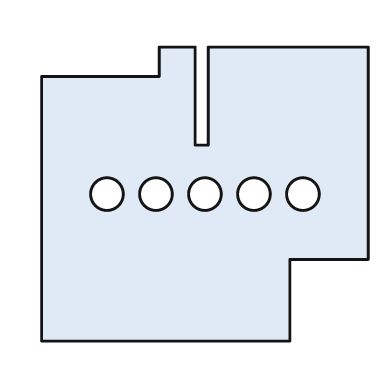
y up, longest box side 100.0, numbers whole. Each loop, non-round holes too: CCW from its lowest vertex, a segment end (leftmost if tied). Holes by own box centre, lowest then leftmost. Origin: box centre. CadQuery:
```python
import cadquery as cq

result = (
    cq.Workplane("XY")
    .moveTo(-50.0, -45.0)
    .lineTo(26.0, -45.0)
    .lineTo(26.0, -20.0)
    .lineTo(50.0, -20.0)
    .lineTo(50.0, 45.0)
    .lineTo(1.0, 45.0)
    .lineTo(1.0, 15.0)
    .lineTo(-3.0, 15.0)
    .lineTo(-3.0, 45.0)
    .lineTo(-14.0, 45.0)
    .lineTo(-14.0, 36.0)
    .lineTo(-50.0, 36.0)
    .close()
    .moveTo(-30.0, 0.0)
    .circle(5.0)
    .moveTo(-15.0, 0.0)
    .circle(5.0)
    .moveTo(0.0, 0.0)
    .circle(5.0)
    .moveTo(15.0, 0.0)
    .circle(5.0)
    .moveTo(30.0, 0.0)
    .circle(5.0)
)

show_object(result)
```